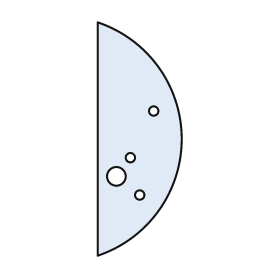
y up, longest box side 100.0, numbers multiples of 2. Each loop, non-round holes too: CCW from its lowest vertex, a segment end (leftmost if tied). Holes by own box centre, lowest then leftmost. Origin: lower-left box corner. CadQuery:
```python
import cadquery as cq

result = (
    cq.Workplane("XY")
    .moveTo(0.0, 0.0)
    .threePointArc((36.0, 50.0), (0.0, 100.0))
    .close()
    .moveTo(18.0, 26.0)
    .circle(2.0)
    .moveTo(8.0, 34.0)
    .circle(4.0)
    .moveTo(14.0, 42.0)
    .circle(2.0)
    .moveTo(24.0, 62.0)
    .circle(2.0)
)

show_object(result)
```